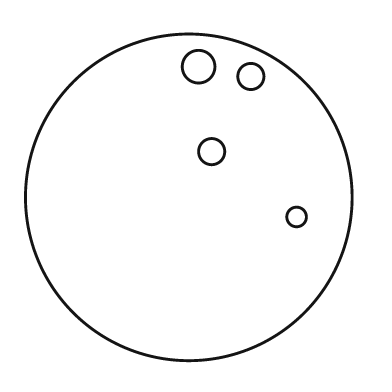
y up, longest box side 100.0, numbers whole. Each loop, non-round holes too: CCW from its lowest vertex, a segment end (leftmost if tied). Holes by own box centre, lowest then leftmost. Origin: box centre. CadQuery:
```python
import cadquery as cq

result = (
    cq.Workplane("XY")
    .moveTo(0.0, 0.0)
    .circle(50.0)
    .moveTo(33.0, -6.0)
    .circle(3.0)
    .moveTo(7.0, 14.0)
    .circle(4.0)
    .moveTo(19.0, 37.0)
    .circle(4.0)
    .moveTo(3.0, 40.0)
    .circle(5.0)
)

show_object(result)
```